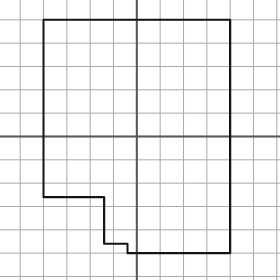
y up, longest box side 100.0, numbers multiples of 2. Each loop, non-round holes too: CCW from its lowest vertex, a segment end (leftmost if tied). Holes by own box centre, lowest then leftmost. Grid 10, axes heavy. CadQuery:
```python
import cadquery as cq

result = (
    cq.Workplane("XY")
    .moveTo(-4.0, -50.0)
    .lineTo(40.0, -50.0)
    .lineTo(40.0, 50.0)
    .lineTo(-40.0, 50.0)
    .lineTo(-40.0, -26.0)
    .lineTo(-14.0, -26.0)
    .lineTo(-14.0, -46.0)
    .lineTo(-4.0, -46.0)
    .close()
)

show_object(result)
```